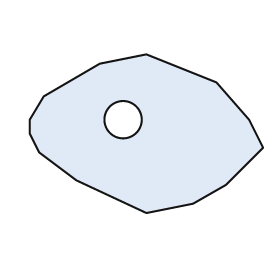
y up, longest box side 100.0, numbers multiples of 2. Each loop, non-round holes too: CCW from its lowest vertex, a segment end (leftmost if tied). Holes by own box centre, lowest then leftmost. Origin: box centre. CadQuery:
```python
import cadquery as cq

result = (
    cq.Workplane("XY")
    .moveTo(0.0, -34.0)
    .lineTo(20.0, -30.0)
    .lineTo(34.0, -22.0)
    .lineTo(50.0, -6.0)
    .lineTo(44.0, 6.0)
    .lineTo(30.0, 22.0)
    .lineTo(0.0, 34.0)
    .lineTo(-20.0, 30.0)
    .lineTo(-44.0, 16.0)
    .lineTo(-50.0, 6.0)
    .lineTo(-50.0, 0.0)
    .lineTo(-46.0, -8.0)
    .lineTo(-30.0, -20.0)
    .close()
    .moveTo(-10.0, 6.0)
    .circle(8.0)
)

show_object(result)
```